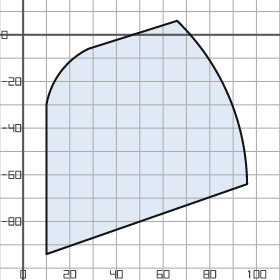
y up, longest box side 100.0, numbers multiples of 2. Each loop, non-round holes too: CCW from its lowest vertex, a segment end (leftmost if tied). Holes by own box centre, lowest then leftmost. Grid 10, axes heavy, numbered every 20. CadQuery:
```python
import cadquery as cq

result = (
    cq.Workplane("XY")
    .moveTo(10.0, -94.0)
    .lineTo(96.0, -64.0)
    .threePointArc((88.0, -26.0), (66.0, 6.0))
    .lineTo(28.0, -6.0)
    .threePointArc((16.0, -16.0), (10.0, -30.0))
    .close()
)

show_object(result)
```